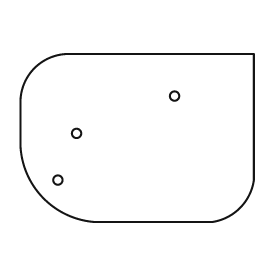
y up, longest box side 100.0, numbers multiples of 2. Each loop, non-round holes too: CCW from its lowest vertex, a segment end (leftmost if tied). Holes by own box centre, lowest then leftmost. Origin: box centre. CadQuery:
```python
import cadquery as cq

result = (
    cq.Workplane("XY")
    .moveTo(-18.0, -36.0)
    .lineTo(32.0, -36.0)
    .threePointArc((44.0, -30.0), (50.0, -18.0))
    .lineTo(50.0, 36.0)
    .lineTo(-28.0, 36.0)
    .threePointArc((-44.0, 30.0), (-50.0, 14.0))
    .lineTo(-50.0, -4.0)
    .threePointArc((-40.0, -26.0), (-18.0, -36.0))
    .close()
    .moveTo(-34.0, -18.0)
    .circle(2.0)
    .moveTo(-26.0, 2.0)
    .circle(2.0)
    .moveTo(16.0, 18.0)
    .circle(2.0)
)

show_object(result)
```